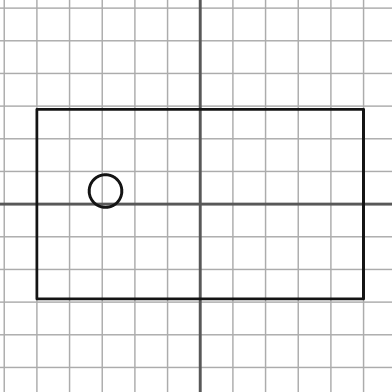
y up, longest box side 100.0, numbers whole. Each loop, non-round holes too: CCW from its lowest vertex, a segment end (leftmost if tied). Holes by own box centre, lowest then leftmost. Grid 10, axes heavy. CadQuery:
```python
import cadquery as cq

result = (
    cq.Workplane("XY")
    .moveTo(-50.0, -29.0)
    .lineTo(50.0, -29.0)
    .lineTo(50.0, 29.0)
    .lineTo(-50.0, 29.0)
    .close()
    .moveTo(-29.0, 4.0)
    .circle(5.0)
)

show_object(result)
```